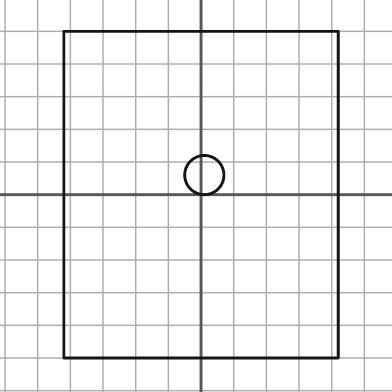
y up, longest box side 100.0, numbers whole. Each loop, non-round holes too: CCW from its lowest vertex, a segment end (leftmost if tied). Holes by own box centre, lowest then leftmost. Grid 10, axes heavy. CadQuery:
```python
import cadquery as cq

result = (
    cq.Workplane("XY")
    .moveTo(-42.0, -50.0)
    .lineTo(42.0, -50.0)
    .lineTo(42.0, 50.0)
    .lineTo(-42.0, 50.0)
    .close()
    .moveTo(1.0, 6.0)
    .circle(6.0)
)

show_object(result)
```